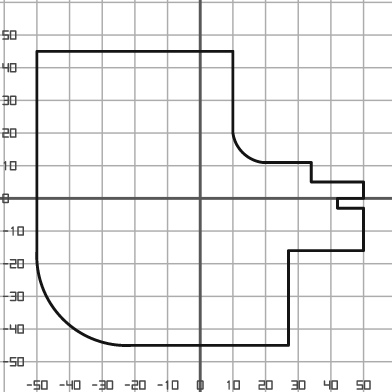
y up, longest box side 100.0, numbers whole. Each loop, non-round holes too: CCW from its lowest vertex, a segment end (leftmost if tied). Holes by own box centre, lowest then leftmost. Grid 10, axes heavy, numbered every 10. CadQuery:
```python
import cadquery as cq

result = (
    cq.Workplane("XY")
    .moveTo(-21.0, -45.0)
    .lineTo(27.0, -45.0)
    .lineTo(27.0, -16.0)
    .lineTo(50.0, -16.0)
    .lineTo(50.0, -3.0)
    .lineTo(42.0, -3.0)
    .lineTo(42.0, 0.0)
    .lineTo(50.0, 0.0)
    .lineTo(50.0, 5.0)
    .lineTo(34.0, 5.0)
    .lineTo(34.0, 11.0)
    .lineTo(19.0, 11.0)
    .threePointArc((13.0, 14.0), (10.0, 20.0))
    .lineTo(10.0, 45.0)
    .lineTo(-50.0, 45.0)
    .lineTo(-50.0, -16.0)
    .threePointArc((-42.0, -37.0), (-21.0, -45.0))
    .close()
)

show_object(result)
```